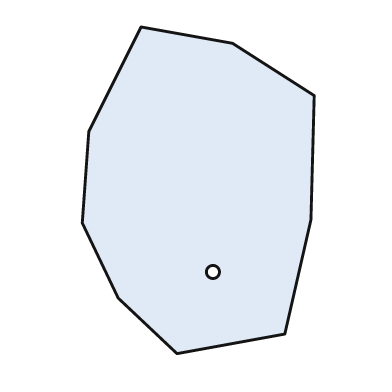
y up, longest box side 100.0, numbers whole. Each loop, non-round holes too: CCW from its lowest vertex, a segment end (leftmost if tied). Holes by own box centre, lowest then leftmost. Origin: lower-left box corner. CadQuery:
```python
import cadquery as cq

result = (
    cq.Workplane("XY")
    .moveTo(29.0, 0.0)
    .lineTo(62.0, 6.0)
    .lineTo(70.0, 41.0)
    .lineTo(71.0, 79.0)
    .lineTo(46.0, 95.0)
    .lineTo(18.0, 100.0)
    .lineTo(2.0, 68.0)
    .lineTo(0.0, 40.0)
    .lineTo(11.0, 17.0)
    .close()
    .moveTo(40.0, 25.0)
    .circle(2.0)
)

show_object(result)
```